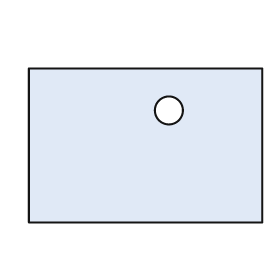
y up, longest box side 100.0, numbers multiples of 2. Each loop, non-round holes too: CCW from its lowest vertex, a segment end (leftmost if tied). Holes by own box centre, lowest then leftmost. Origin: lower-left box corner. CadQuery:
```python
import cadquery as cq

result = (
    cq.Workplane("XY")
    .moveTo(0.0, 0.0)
    .lineTo(100.0, 0.0)
    .lineTo(100.0, 66.0)
    .lineTo(0.0, 66.0)
    .close()
    .moveTo(60.0, 48.0)
    .circle(6.0)
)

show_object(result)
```